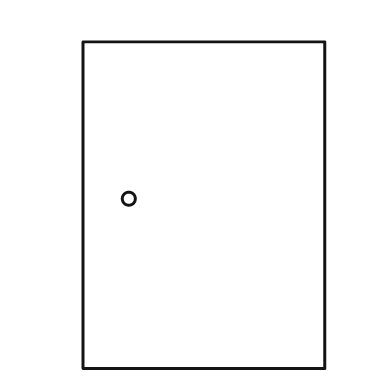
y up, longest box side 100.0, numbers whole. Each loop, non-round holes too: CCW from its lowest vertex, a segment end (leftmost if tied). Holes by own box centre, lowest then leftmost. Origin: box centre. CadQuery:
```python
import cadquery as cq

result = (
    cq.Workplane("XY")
    .moveTo(-37.0, -50.0)
    .lineTo(37.0, -50.0)
    .lineTo(37.0, 50.0)
    .lineTo(-37.0, 50.0)
    .close()
    .moveTo(-23.0, 2.0)
    .circle(2.0)
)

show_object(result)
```